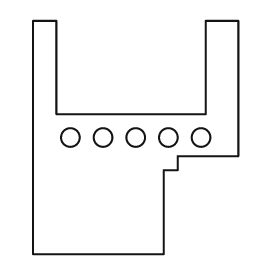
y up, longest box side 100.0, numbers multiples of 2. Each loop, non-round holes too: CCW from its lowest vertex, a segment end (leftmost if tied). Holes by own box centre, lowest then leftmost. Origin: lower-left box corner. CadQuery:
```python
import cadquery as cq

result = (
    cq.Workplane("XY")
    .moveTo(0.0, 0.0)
    .lineTo(56.0, 0.0)
    .lineTo(56.0, 36.0)
    .lineTo(62.0, 36.0)
    .lineTo(62.0, 42.0)
    .lineTo(88.0, 42.0)
    .lineTo(88.0, 100.0)
    .lineTo(74.0, 100.0)
    .lineTo(74.0, 60.0)
    .lineTo(10.0, 60.0)
    .lineTo(10.0, 100.0)
    .lineTo(0.0, 100.0)
    .close()
    .moveTo(16.0, 50.0)
    .circle(4.0)
    .moveTo(30.0, 50.0)
    .circle(4.0)
    .moveTo(44.0, 50.0)
    .circle(4.0)
    .moveTo(58.0, 50.0)
    .circle(4.0)
    .moveTo(72.0, 50.0)
    .circle(4.0)
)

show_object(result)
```